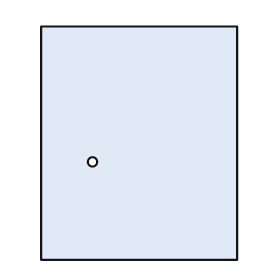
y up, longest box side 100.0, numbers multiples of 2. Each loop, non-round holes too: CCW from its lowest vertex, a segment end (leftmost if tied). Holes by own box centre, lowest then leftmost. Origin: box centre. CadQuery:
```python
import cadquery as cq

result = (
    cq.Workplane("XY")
    .moveTo(-42.0, -50.0)
    .lineTo(42.0, -50.0)
    .lineTo(42.0, 50.0)
    .lineTo(-42.0, 50.0)
    .close()
    .moveTo(-20.0, -8.0)
    .circle(2.0)
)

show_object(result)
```